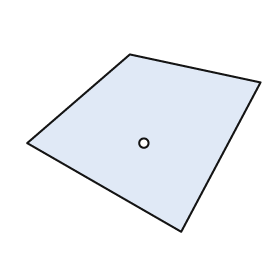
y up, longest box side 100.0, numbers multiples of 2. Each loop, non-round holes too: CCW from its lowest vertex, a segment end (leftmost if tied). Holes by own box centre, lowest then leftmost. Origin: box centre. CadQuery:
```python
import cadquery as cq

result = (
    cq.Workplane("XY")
    .moveTo(16.0, -38.0)
    .lineTo(50.0, 26.0)
    .lineTo(-6.0, 38.0)
    .lineTo(-50.0, 0.0)
    .close()
    .moveTo(0.0, 0.0)
    .circle(2.0)
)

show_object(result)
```